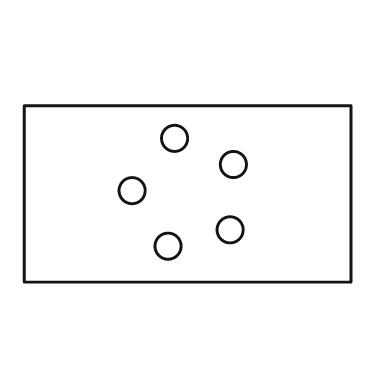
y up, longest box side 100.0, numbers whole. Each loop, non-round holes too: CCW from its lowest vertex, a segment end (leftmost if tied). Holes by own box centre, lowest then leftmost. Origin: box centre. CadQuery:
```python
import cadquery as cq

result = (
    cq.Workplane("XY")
    .moveTo(-50.0, -27.0)
    .lineTo(50.0, -27.0)
    .lineTo(50.0, 27.0)
    .lineTo(-50.0, 27.0)
    .close()
    .moveTo(-6.0, -16.0)
    .circle(4.0)
    .moveTo(13.0, -11.0)
    .circle(4.0)
    .moveTo(-17.0, 1.0)
    .circle(4.0)
    .moveTo(14.0, 9.0)
    .circle(4.0)
    .moveTo(-4.0, 17.0)
    .circle(4.0)
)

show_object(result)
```